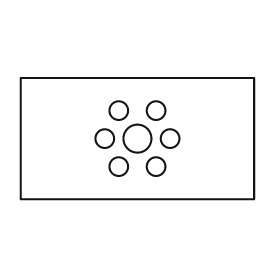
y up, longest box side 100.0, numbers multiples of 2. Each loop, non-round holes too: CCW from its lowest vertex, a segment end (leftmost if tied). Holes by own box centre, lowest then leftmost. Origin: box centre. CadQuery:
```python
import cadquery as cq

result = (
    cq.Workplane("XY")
    .moveTo(-50.0, -26.0)
    .lineTo(50.0, -26.0)
    .lineTo(50.0, 26.0)
    .lineTo(-50.0, 26.0)
    .close()
    .moveTo(-8.0, -12.0)
    .circle(4.0)
    .moveTo(8.0, -12.0)
    .circle(4.0)
    .moveTo(-14.0, 0.0)
    .circle(4.0)
    .moveTo(0.0, 0.0)
    .circle(6.0)
    .moveTo(14.0, 0.0)
    .circle(4.0)
    .moveTo(-8.0, 12.0)
    .circle(4.0)
    .moveTo(8.0, 12.0)
    .circle(4.0)
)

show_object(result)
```